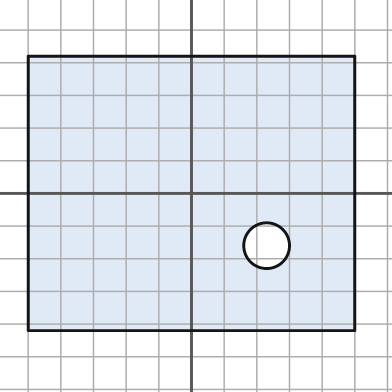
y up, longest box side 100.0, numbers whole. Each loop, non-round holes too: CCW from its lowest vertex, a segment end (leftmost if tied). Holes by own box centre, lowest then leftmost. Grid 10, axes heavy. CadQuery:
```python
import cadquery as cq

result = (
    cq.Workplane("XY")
    .moveTo(-50.0, -42.0)
    .lineTo(50.0, -42.0)
    .lineTo(50.0, 42.0)
    .lineTo(-50.0, 42.0)
    .close()
    .moveTo(23.0, -16.0)
    .circle(7.0)
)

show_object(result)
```